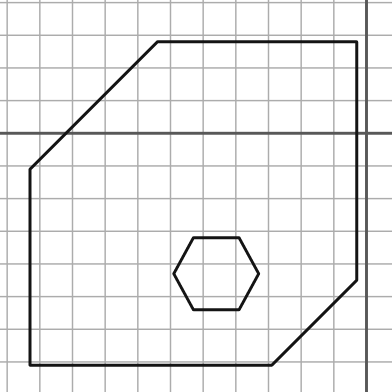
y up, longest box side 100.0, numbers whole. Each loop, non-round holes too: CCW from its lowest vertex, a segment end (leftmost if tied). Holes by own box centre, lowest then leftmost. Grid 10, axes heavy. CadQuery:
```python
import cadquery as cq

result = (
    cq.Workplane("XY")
    .moveTo(-103.0, -71.0)
    .lineTo(-29.0, -71.0)
    .lineTo(-3.0, -45.0)
    .lineTo(-3.0, 28.0)
    .lineTo(-64.0, 28.0)
    .lineTo(-103.0, -11.0)
    .close()
    .moveTo(-53.0, -54.0)
    .lineTo(-39.0, -54.0)
    .lineTo(-33.0, -43.0)
    .lineTo(-39.0, -32.0)
    .lineTo(-53.0, -32.0)
    .lineTo(-59.0, -43.0)
    .close()
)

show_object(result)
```